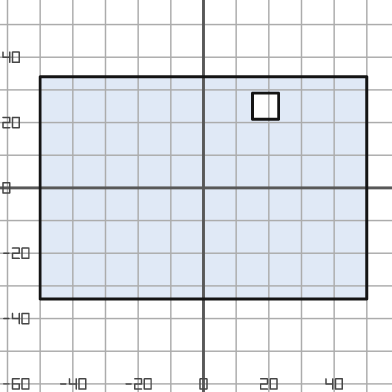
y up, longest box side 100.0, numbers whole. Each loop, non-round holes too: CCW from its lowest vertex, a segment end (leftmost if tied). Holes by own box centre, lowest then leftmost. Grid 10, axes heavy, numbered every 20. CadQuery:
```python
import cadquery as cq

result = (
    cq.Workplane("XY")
    .moveTo(-50.0, -34.0)
    .lineTo(50.0, -34.0)
    .lineTo(50.0, 34.0)
    .lineTo(-50.0, 34.0)
    .close()
    .moveTo(15.0, 21.0)
    .lineTo(23.0, 21.0)
    .lineTo(23.0, 29.0)
    .lineTo(15.0, 29.0)
    .close()
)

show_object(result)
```